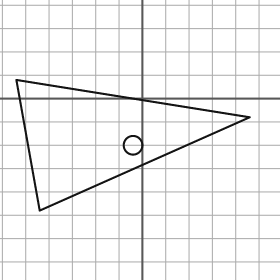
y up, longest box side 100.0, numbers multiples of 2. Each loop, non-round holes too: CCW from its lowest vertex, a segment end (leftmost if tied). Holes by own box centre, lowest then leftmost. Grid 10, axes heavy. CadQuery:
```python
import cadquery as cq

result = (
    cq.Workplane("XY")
    .moveTo(-44.0, -48.0)
    .lineTo(46.0, -8.0)
    .lineTo(-54.0, 8.0)
    .close()
    .moveTo(-4.0, -20.0)
    .circle(4.0)
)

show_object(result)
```